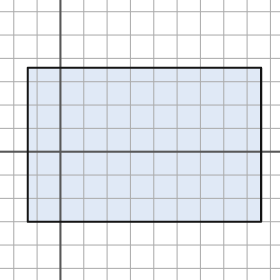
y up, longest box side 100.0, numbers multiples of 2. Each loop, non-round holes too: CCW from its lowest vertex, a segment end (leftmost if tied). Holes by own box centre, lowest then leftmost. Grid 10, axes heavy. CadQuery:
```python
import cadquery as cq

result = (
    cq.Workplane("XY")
    .moveTo(-14.0, -30.0)
    .lineTo(86.0, -30.0)
    .lineTo(86.0, 36.0)
    .lineTo(-14.0, 36.0)
    .close()
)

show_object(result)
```